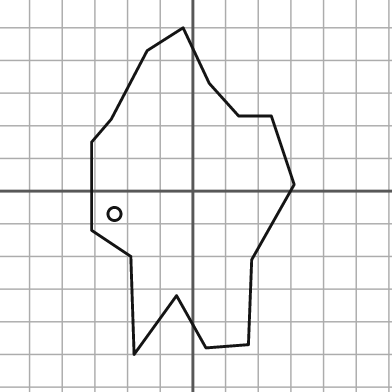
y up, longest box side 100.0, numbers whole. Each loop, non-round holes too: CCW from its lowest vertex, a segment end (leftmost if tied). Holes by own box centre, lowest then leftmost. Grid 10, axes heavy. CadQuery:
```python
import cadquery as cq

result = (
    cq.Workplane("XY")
    .moveTo(-18.0, -50.0)
    .lineTo(-5.0, -32.0)
    .lineTo(4.0, -48.0)
    .lineTo(17.0, -47.0)
    .lineTo(18.0, -21.0)
    .lineTo(31.0, 2.0)
    .lineTo(24.0, 23.0)
    .lineTo(14.0, 23.0)
    .lineTo(5.0, 33.0)
    .lineTo(-3.0, 50.0)
    .lineTo(-14.0, 43.0)
    .lineTo(-25.0, 22.0)
    .lineTo(-31.0, 15.0)
    .lineTo(-31.0, -12.0)
    .lineTo(-19.0, -20.0)
    .close()
    .moveTo(-24.0, -7.0)
    .circle(2.0)
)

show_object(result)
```